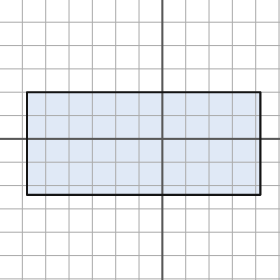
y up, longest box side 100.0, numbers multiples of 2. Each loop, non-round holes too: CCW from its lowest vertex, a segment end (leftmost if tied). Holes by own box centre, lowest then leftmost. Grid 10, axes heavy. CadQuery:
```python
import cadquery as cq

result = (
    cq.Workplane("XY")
    .moveTo(-58.0, -24.0)
    .lineTo(42.0, -24.0)
    .lineTo(42.0, 20.0)
    .lineTo(-58.0, 20.0)
    .close()
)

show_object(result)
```